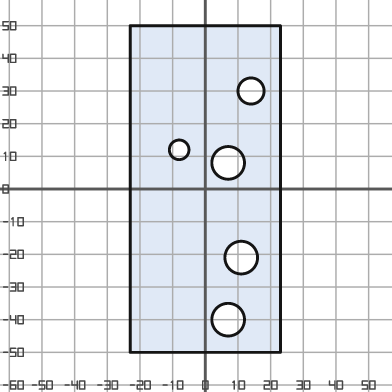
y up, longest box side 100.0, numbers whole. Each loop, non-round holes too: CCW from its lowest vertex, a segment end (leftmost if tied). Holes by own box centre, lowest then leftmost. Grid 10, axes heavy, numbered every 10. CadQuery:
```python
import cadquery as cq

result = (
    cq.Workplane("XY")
    .moveTo(-23.0, -50.0)
    .lineTo(23.0, -50.0)
    .lineTo(23.0, 50.0)
    .lineTo(-23.0, 50.0)
    .close()
    .moveTo(7.0, -40.0)
    .circle(5.0)
    .moveTo(11.0, -21.0)
    .circle(5.0)
    .moveTo(7.0, 8.0)
    .circle(5.0)
    .moveTo(-8.0, 12.0)
    .circle(3.0)
    .moveTo(14.0, 30.0)
    .circle(4.0)
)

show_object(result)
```